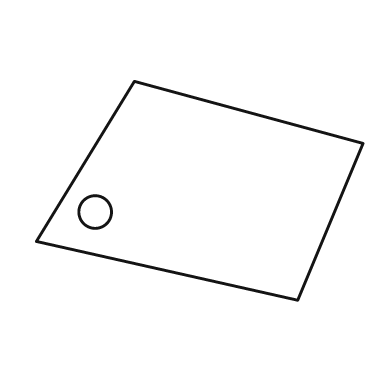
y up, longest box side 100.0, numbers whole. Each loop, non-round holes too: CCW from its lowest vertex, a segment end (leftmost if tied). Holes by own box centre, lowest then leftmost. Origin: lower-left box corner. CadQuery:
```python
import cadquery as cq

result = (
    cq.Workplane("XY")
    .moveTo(80.0, 0.0)
    .lineTo(100.0, 48.0)
    .lineTo(30.0, 67.0)
    .lineTo(0.0, 18.0)
    .close()
    .moveTo(18.0, 27.0)
    .circle(5.0)
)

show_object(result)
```